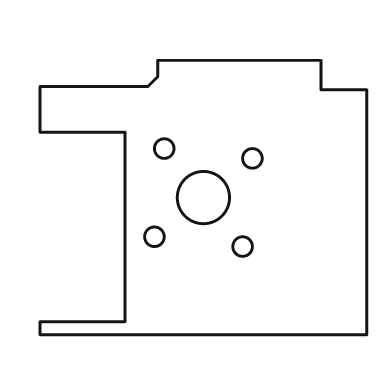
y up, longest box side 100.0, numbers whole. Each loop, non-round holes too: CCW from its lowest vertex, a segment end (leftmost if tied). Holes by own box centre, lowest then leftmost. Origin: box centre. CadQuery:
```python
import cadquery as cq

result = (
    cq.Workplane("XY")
    .moveTo(-50.0, -42.0)
    .lineTo(50.0, -42.0)
    .lineTo(50.0, 33.0)
    .lineTo(36.0, 33.0)
    .lineTo(36.0, 42.0)
    .lineTo(-14.0, 42.0)
    .lineTo(-14.0, 37.0)
    .lineTo(-17.0, 34.0)
    .lineTo(-50.0, 34.0)
    .lineTo(-50.0, 20.0)
    .lineTo(-24.0, 20.0)
    .lineTo(-24.0, -38.0)
    .lineTo(-50.0, -38.0)
    .close()
    .moveTo(12.0, -15.0)
    .circle(3.0)
    .moveTo(-15.0, -12.0)
    .circle(3.0)
    .moveTo(0.0, 0.0)
    .circle(8.0)
    .moveTo(15.0, 12.0)
    .circle(3.0)
    .moveTo(-12.0, 15.0)
    .circle(3.0)
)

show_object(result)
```